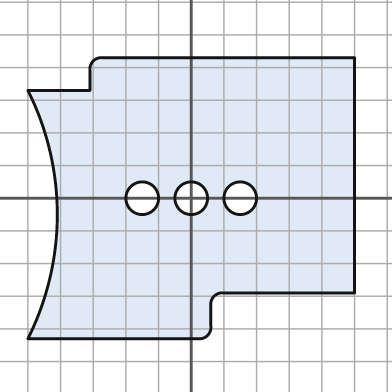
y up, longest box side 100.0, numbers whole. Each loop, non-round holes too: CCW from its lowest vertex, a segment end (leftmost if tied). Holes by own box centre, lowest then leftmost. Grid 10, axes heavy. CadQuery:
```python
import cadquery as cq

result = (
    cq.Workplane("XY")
    .moveTo(-50.0, -43.0)
    .lineTo(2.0, -43.0)
    .threePointArc((5.0, -42.0), (6.0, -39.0))
    .lineTo(6.0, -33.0)
    .threePointArc((7.0, -30.0), (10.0, -29.0))
    .lineTo(50.0, -29.0)
    .lineTo(50.0, 43.0)
    .lineTo(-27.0, 43.0)
    .threePointArc((-30.0, 42.0), (-31.0, 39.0))
    .lineTo(-31.0, 33.0)
    .lineTo(-50.0, 33.0)
    .threePointArc((-41.0, -5.0), (-50.0, -43.0))
    .close()
    .moveTo(-15.0, 0.0)
    .circle(5.0)
    .moveTo(0.0, 0.0)
    .circle(5.0)
    .moveTo(15.0, 0.0)
    .circle(5.0)
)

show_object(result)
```